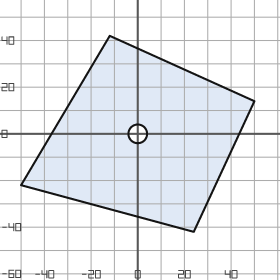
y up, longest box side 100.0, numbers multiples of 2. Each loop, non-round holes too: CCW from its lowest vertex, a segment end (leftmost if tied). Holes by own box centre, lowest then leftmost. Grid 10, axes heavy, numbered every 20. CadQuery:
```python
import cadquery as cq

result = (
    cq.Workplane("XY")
    .moveTo(24.0, -42.0)
    .lineTo(50.0, 14.0)
    .lineTo(-12.0, 42.0)
    .lineTo(-50.0, -22.0)
    .close()
    .moveTo(0.0, 0.0)
    .circle(4.0)
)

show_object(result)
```